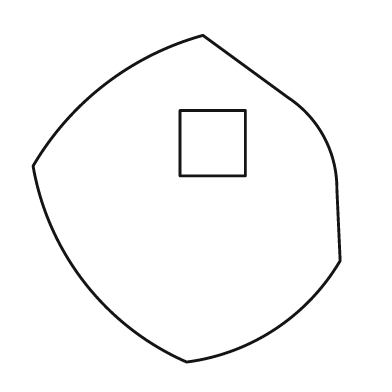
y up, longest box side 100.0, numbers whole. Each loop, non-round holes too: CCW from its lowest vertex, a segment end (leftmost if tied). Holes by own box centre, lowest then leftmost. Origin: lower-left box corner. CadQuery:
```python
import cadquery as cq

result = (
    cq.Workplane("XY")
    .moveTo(47.0, 0.0)
    .threePointArc((74.0, 10.0), (94.0, 31.0))
    .lineTo(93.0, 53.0)
    .threePointArc((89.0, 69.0), (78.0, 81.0))
    .lineTo(52.0, 100.0)
    .threePointArc((22.0, 85.0), (0.0, 60.0))
    .threePointArc((16.0, 24.0), (47.0, 0.0))
    .close()
    .moveTo(45.0, 57.0)
    .lineTo(65.0, 57.0)
    .lineTo(65.0, 77.0)
    .lineTo(45.0, 77.0)
    .close()
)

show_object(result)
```